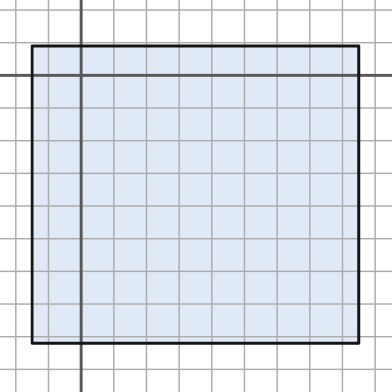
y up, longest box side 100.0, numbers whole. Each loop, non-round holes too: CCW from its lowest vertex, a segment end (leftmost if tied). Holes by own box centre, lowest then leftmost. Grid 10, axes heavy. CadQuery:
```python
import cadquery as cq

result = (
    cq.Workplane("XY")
    .moveTo(-15.0, -82.0)
    .lineTo(85.0, -82.0)
    .lineTo(85.0, 9.0)
    .lineTo(-15.0, 9.0)
    .close()
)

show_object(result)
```